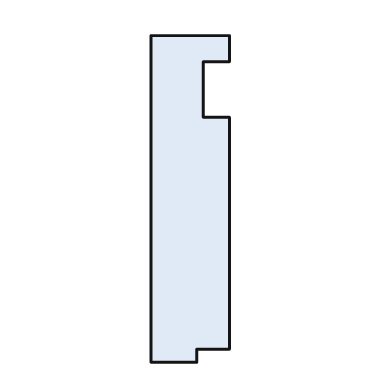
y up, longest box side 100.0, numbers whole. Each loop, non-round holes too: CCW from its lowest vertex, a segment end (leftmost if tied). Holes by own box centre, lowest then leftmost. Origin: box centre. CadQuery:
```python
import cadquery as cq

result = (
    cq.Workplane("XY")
    .moveTo(-12.0, -50.0)
    .lineTo(2.0, -50.0)
    .lineTo(2.0, -46.0)
    .lineTo(12.0, -46.0)
    .lineTo(12.0, 25.0)
    .lineTo(4.0, 25.0)
    .lineTo(4.0, 42.0)
    .lineTo(12.0, 42.0)
    .lineTo(12.0, 50.0)
    .lineTo(-12.0, 50.0)
    .close()
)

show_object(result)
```